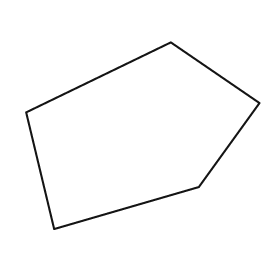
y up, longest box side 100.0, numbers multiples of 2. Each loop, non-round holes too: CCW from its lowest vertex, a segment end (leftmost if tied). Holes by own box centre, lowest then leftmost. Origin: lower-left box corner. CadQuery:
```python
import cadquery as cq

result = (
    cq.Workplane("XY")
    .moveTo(12.0, 0.0)
    .lineTo(74.0, 18.0)
    .lineTo(100.0, 54.0)
    .lineTo(62.0, 80.0)
    .lineTo(0.0, 50.0)
    .close()
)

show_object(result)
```